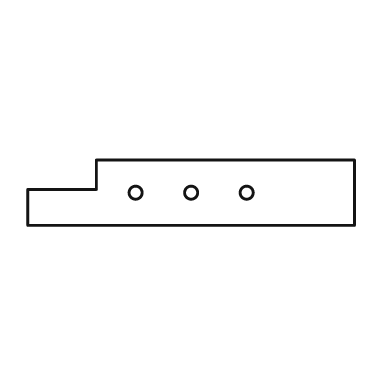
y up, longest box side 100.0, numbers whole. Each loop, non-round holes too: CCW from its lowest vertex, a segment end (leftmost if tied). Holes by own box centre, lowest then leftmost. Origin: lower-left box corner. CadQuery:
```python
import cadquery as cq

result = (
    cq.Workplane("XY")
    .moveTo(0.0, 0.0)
    .lineTo(100.0, 0.0)
    .lineTo(100.0, 20.0)
    .lineTo(21.0, 20.0)
    .lineTo(21.0, 11.0)
    .lineTo(0.0, 11.0)
    .close()
    .moveTo(33.0, 10.0)
    .circle(2.0)
    .moveTo(50.0, 10.0)
    .circle(2.0)
    .moveTo(67.0, 10.0)
    .circle(2.0)
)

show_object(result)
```